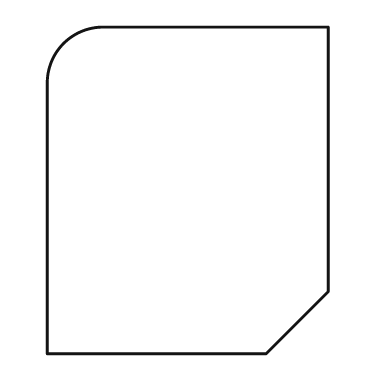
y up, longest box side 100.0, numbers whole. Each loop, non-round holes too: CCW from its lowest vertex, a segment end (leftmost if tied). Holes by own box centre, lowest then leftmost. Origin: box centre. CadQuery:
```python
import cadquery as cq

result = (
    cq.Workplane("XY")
    .moveTo(-43.0, -50.0)
    .lineTo(24.0, -50.0)
    .lineTo(43.0, -31.0)
    .lineTo(43.0, 50.0)
    .lineTo(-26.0, 50.0)
    .threePointArc((-38.0, 45.0), (-43.0, 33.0))
    .close()
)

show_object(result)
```